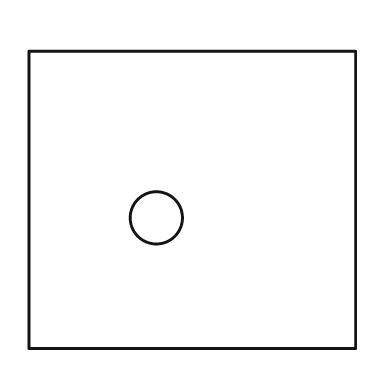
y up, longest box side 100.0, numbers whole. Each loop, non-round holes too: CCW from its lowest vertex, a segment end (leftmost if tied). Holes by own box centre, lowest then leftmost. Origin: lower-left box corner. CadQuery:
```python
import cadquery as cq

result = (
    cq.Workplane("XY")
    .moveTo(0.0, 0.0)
    .lineTo(100.0, 0.0)
    .lineTo(100.0, 91.0)
    .lineTo(0.0, 91.0)
    .close()
    .moveTo(39.0, 40.0)
    .circle(8.0)
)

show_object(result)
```